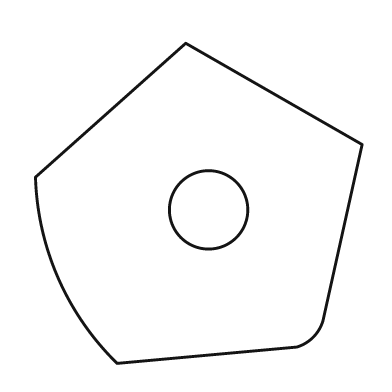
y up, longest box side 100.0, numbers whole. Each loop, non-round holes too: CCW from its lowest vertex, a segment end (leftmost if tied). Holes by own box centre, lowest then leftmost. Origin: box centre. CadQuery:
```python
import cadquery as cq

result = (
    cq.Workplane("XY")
    .moveTo(-25.0, -49.0)
    .lineTo(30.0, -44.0)
    .threePointArc((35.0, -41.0), (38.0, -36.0))
    .lineTo(50.0, 18.0)
    .lineTo(-4.0, 49.0)
    .lineTo(-50.0, 8.0)
    .threePointArc((-43.0, -23.0), (-25.0, -49.0))
    .close()
    .moveTo(3.0, -2.0)
    .circle(12.0)
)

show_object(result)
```